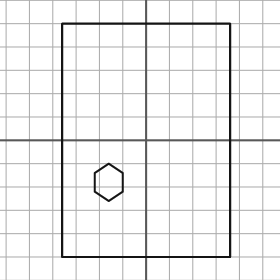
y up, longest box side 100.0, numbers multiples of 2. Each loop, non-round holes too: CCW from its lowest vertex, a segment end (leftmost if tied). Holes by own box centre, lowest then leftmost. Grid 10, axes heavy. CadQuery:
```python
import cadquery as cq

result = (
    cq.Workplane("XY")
    .moveTo(-36.0, -50.0)
    .lineTo(36.0, -50.0)
    .lineTo(36.0, 50.0)
    .lineTo(-36.0, 50.0)
    .close()
    .moveTo(-16.0, -26.0)
    .lineTo(-10.0, -22.0)
    .lineTo(-10.0, -14.0)
    .lineTo(-16.0, -10.0)
    .lineTo(-22.0, -14.0)
    .lineTo(-22.0, -22.0)
    .close()
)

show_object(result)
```